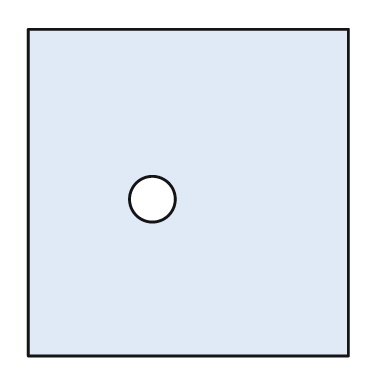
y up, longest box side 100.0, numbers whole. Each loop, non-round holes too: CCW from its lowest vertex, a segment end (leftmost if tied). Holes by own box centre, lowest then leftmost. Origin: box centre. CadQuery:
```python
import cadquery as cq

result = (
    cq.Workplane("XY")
    .moveTo(-49.0, -50.0)
    .lineTo(49.0, -50.0)
    .lineTo(49.0, 50.0)
    .lineTo(-49.0, 50.0)
    .close()
    .moveTo(-11.0, -2.0)
    .circle(7.0)
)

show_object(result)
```